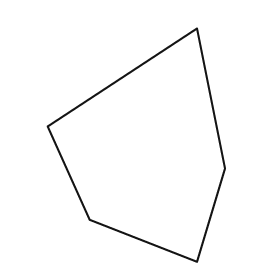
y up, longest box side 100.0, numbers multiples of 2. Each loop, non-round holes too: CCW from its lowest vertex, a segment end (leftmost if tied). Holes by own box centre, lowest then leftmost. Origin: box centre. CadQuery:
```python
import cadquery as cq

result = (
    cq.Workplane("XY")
    .moveTo(26.0, -50.0)
    .lineTo(38.0, -10.0)
    .lineTo(26.0, 50.0)
    .lineTo(-38.0, 8.0)
    .lineTo(-20.0, -32.0)
    .close()
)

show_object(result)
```